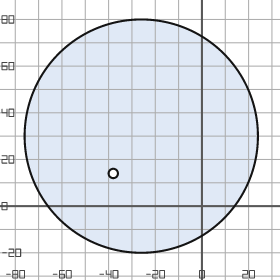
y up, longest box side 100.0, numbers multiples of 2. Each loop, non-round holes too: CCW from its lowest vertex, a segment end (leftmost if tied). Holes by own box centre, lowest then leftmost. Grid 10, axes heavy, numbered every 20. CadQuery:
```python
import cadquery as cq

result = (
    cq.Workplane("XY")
    .moveTo(-26.0, 30.0)
    .circle(50.0)
    .moveTo(-38.0, 14.0)
    .circle(2.0)
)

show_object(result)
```